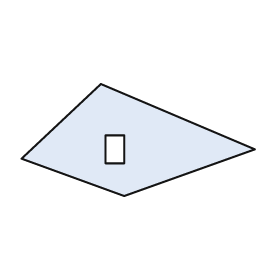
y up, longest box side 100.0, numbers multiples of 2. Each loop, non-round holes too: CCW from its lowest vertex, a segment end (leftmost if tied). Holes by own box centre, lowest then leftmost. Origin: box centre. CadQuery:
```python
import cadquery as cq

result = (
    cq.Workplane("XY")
    .moveTo(-6.0, -24.0)
    .lineTo(50.0, -4.0)
    .lineTo(-16.0, 24.0)
    .lineTo(-50.0, -8.0)
    .close()
    .moveTo(-14.0, -10.0)
    .lineTo(-6.0, -10.0)
    .lineTo(-6.0, 2.0)
    .lineTo(-14.0, 2.0)
    .close()
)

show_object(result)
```